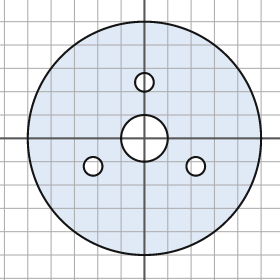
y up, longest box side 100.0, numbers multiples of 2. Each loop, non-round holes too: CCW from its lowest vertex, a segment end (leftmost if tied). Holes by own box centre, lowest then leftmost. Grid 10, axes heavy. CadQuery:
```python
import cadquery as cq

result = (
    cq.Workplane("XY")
    .moveTo(0.0, 0.0)
    .circle(50.0)
    .moveTo(-22.0, -12.0)
    .circle(4.0)
    .moveTo(22.0, -12.0)
    .circle(4.0)
    .moveTo(0.0, 0.0)
    .circle(10.0)
    .moveTo(0.0, 24.0)
    .circle(4.0)
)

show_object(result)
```